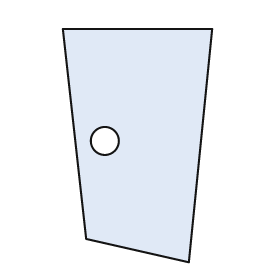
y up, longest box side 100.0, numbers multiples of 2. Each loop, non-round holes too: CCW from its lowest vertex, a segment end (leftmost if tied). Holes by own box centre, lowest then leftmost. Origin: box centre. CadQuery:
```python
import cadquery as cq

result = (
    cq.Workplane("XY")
    .moveTo(22.0, -50.0)
    .lineTo(32.0, 50.0)
    .lineTo(-32.0, 50.0)
    .lineTo(-22.0, -40.0)
    .close()
    .moveTo(-14.0, 2.0)
    .circle(6.0)
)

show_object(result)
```